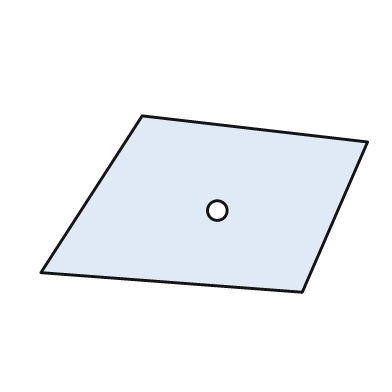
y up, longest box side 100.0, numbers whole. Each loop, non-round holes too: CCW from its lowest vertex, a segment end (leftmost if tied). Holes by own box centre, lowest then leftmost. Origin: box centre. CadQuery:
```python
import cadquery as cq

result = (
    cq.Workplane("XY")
    .moveTo(30.0, -27.0)
    .lineTo(50.0, 19.0)
    .lineTo(-19.0, 27.0)
    .lineTo(-50.0, -21.0)
    .close()
    .moveTo(4.0, -2.0)
    .circle(3.0)
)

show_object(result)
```